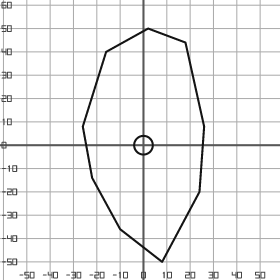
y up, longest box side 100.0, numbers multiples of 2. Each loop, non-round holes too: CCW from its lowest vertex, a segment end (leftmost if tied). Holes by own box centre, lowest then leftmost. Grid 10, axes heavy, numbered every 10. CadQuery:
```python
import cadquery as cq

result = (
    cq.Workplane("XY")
    .moveTo(8.0, -50.0)
    .lineTo(24.0, -20.0)
    .lineTo(26.0, 8.0)
    .lineTo(18.0, 44.0)
    .lineTo(2.0, 50.0)
    .lineTo(-16.0, 40.0)
    .lineTo(-26.0, 8.0)
    .lineTo(-22.0, -14.0)
    .lineTo(-10.0, -36.0)
    .close()
    .moveTo(0.0, 0.0)
    .circle(4.0)
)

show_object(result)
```